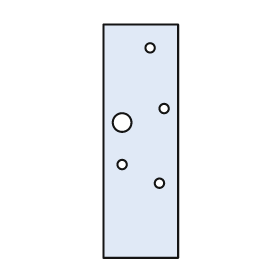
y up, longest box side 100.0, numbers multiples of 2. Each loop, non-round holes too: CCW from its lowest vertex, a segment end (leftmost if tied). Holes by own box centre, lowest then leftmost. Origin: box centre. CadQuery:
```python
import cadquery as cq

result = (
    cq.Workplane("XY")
    .moveTo(-16.0, -50.0)
    .lineTo(16.0, -50.0)
    .lineTo(16.0, 50.0)
    .lineTo(-16.0, 50.0)
    .close()
    .moveTo(8.0, -18.0)
    .circle(2.0)
    .moveTo(-8.0, -10.0)
    .circle(2.0)
    .moveTo(-8.0, 8.0)
    .circle(4.0)
    .moveTo(10.0, 14.0)
    .circle(2.0)
    .moveTo(4.0, 40.0)
    .circle(2.0)
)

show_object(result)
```